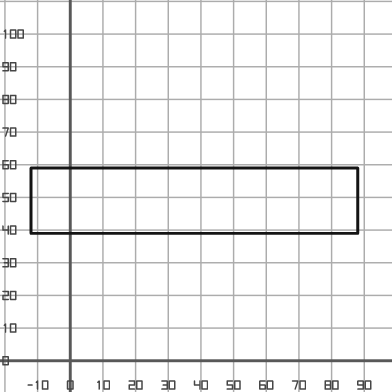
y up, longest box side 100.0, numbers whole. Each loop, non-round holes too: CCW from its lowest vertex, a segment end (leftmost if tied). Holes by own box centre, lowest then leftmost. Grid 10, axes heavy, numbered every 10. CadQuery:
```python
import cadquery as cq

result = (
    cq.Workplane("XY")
    .moveTo(-12.0, 39.0)
    .lineTo(88.0, 39.0)
    .lineTo(88.0, 59.0)
    .lineTo(-12.0, 59.0)
    .close()
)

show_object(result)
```